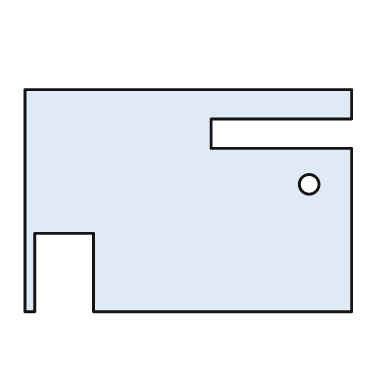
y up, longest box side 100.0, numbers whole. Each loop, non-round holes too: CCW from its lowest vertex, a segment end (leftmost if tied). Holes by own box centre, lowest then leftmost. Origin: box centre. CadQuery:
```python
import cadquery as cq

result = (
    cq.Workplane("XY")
    .moveTo(-50.0, -34.0)
    .lineTo(-47.0, -34.0)
    .lineTo(-47.0, -10.0)
    .lineTo(-29.0, -10.0)
    .lineTo(-29.0, -34.0)
    .lineTo(50.0, -34.0)
    .lineTo(50.0, 16.0)
    .lineTo(7.0, 16.0)
    .lineTo(7.0, 25.0)
    .lineTo(50.0, 25.0)
    .lineTo(50.0, 34.0)
    .lineTo(-50.0, 34.0)
    .close()
    .moveTo(37.0, 5.0)
    .circle(3.0)
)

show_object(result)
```